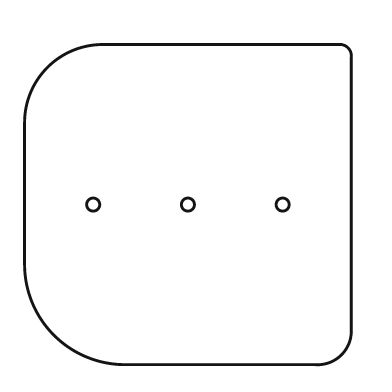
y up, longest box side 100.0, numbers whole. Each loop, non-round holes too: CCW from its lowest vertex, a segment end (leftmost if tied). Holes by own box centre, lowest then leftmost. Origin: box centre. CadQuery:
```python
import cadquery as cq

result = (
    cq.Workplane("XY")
    .moveTo(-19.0, -49.0)
    .lineTo(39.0, -49.0)
    .threePointArc((47.0, -46.0), (50.0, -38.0))
    .lineTo(50.0, 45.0)
    .threePointArc((49.0, 48.0), (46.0, 49.0))
    .lineTo(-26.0, 49.0)
    .threePointArc((-43.0, 42.0), (-50.0, 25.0))
    .lineTo(-50.0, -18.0)
    .threePointArc((-41.0, -40.0), (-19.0, -49.0))
    .close()
    .moveTo(-29.0, 0.0)
    .circle(2.0)
    .moveTo(0.0, 0.0)
    .circle(2.0)
    .moveTo(29.0, 0.0)
    .circle(2.0)
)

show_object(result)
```